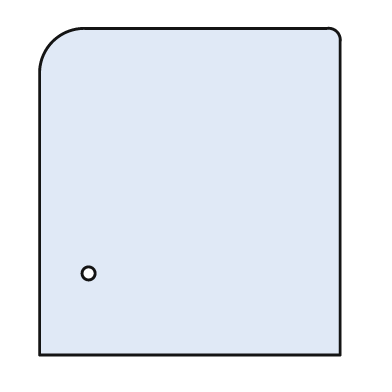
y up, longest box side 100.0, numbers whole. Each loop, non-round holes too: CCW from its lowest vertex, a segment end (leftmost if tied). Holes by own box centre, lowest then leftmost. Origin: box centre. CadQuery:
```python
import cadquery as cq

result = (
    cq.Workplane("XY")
    .moveTo(-46.0, -50.0)
    .lineTo(46.0, -50.0)
    .lineTo(46.0, 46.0)
    .threePointArc((45.0, 49.0), (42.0, 50.0))
    .lineTo(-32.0, 50.0)
    .threePointArc((-42.0, 46.0), (-46.0, 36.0))
    .close()
    .moveTo(-31.0, -25.0)
    .circle(2.0)
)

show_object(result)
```